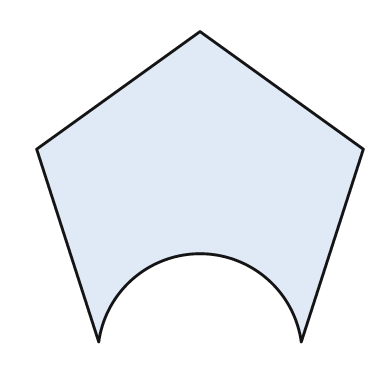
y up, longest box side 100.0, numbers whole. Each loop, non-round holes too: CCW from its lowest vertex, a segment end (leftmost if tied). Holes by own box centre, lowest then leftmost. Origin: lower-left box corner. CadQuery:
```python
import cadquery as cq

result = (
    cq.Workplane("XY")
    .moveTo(19.0, 0.0)
    .threePointArc((50.0, 27.0), (81.0, 0.0))
    .lineTo(100.0, 59.0)
    .lineTo(50.0, 95.0)
    .lineTo(0.0, 59.0)
    .close()
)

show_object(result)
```